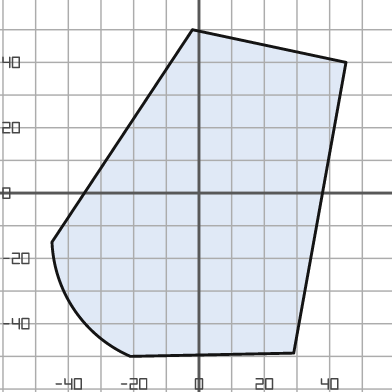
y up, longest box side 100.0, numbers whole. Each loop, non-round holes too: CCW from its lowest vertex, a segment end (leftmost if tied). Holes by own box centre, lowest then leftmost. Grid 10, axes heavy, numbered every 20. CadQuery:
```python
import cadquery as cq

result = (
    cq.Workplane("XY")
    .moveTo(-21.0, -50.0)
    .lineTo(29.0, -49.0)
    .lineTo(45.0, 40.0)
    .lineTo(-2.0, 50.0)
    .lineTo(-45.0, -15.0)
    .threePointArc((-38.0, -36.0), (-21.0, -50.0))
    .close()
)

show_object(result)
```